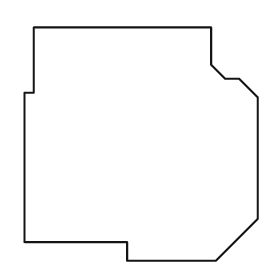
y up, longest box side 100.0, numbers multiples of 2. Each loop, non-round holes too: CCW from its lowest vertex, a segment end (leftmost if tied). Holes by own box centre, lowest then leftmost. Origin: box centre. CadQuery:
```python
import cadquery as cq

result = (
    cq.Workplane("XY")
    .moveTo(-6.0, -50.0)
    .lineTo(32.0, -50.0)
    .lineTo(50.0, -32.0)
    .lineTo(50.0, 20.0)
    .lineTo(42.0, 28.0)
    .lineTo(36.0, 28.0)
    .lineTo(30.0, 34.0)
    .lineTo(30.0, 50.0)
    .lineTo(-46.0, 50.0)
    .lineTo(-46.0, 22.0)
    .lineTo(-50.0, 22.0)
    .lineTo(-50.0, -42.0)
    .lineTo(-6.0, -42.0)
    .close()
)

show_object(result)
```